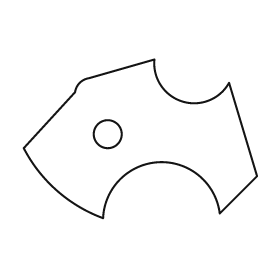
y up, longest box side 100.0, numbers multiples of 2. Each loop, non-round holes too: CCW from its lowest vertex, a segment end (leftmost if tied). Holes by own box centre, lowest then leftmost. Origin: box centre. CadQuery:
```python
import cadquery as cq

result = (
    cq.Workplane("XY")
    .moveTo(-16.0, -34.0)
    .threePointArc((8.0, -10.0), (34.0, -32.0))
    .lineTo(50.0, -16.0)
    .lineTo(38.0, 24.0)
    .threePointArc((18.0, 16.0), (6.0, 34.0))
    .lineTo(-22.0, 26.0)
    .threePointArc((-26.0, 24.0), (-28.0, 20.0))
    .lineTo(-50.0, -4.0)
    .threePointArc((-36.0, -22.0), (-16.0, -34.0))
    .close()
    .moveTo(-14.0, 2.0)
    .circle(6.0)
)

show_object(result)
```